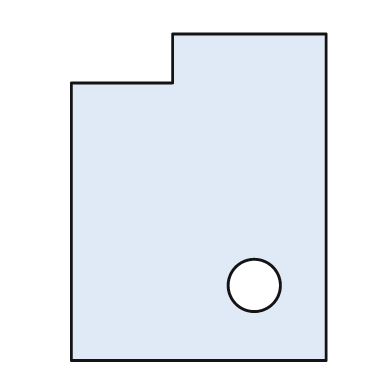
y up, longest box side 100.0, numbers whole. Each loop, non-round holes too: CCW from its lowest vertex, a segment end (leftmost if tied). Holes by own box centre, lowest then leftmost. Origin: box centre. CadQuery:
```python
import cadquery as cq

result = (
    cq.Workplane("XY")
    .moveTo(-39.0, -50.0)
    .lineTo(39.0, -50.0)
    .lineTo(39.0, 50.0)
    .lineTo(-8.0, 50.0)
    .lineTo(-8.0, 35.0)
    .lineTo(-39.0, 35.0)
    .close()
    .moveTo(17.0, -27.0)
    .circle(8.0)
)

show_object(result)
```